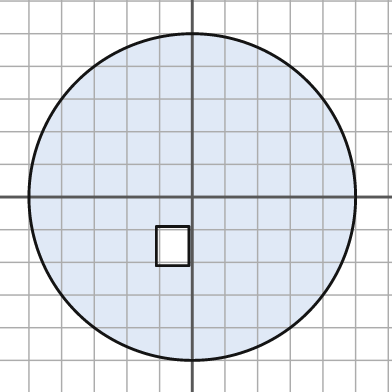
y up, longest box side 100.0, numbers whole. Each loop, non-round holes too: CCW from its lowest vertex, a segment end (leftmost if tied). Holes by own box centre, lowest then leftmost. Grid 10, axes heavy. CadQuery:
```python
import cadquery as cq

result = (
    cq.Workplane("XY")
    .moveTo(0.0, 0.0)
    .circle(50.0)
    .moveTo(-11.0, -21.0)
    .lineTo(-1.0, -21.0)
    .lineTo(-1.0, -9.0)
    .lineTo(-11.0, -9.0)
    .close()
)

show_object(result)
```